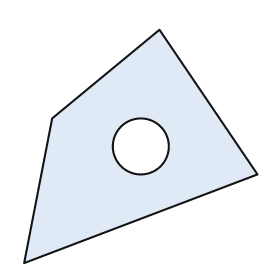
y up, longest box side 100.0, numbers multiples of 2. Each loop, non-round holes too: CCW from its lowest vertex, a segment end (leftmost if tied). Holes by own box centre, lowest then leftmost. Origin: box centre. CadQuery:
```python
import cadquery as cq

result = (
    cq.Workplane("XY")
    .moveTo(-50.0, -50.0)
    .lineTo(50.0, -12.0)
    .lineTo(8.0, 50.0)
    .lineTo(-38.0, 12.0)
    .close()
    .moveTo(0.0, 0.0)
    .circle(12.0)
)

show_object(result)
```